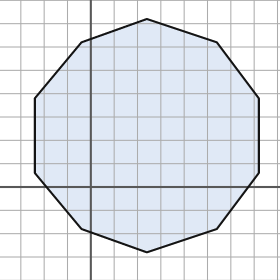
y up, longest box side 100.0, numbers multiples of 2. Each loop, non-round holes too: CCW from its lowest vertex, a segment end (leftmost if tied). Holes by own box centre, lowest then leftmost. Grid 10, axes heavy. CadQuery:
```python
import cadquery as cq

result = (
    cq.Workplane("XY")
    .moveTo(24.0, -28.0)
    .lineTo(54.0, -18.0)
    .lineTo(72.0, 6.0)
    .lineTo(72.0, 38.0)
    .lineTo(54.0, 62.0)
    .lineTo(24.0, 72.0)
    .lineTo(-4.0, 62.0)
    .lineTo(-24.0, 38.0)
    .lineTo(-24.0, 6.0)
    .lineTo(-4.0, -18.0)
    .close()
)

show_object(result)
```